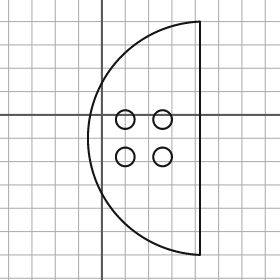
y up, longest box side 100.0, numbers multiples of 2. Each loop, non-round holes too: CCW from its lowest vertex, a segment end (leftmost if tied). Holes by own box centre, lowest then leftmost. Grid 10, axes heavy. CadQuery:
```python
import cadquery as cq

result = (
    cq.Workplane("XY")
    .moveTo(42.0, -60.0)
    .lineTo(42.0, 40.0)
    .threePointArc((-6.0, -10.0), (42.0, -60.0))
    .close()
    .moveTo(10.0, -18.0)
    .circle(4.0)
    .moveTo(26.0, -18.0)
    .circle(4.0)
    .moveTo(10.0, -2.0)
    .circle(4.0)
    .moveTo(26.0, -2.0)
    .circle(4.0)
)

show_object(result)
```